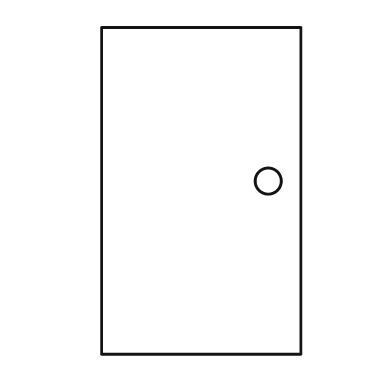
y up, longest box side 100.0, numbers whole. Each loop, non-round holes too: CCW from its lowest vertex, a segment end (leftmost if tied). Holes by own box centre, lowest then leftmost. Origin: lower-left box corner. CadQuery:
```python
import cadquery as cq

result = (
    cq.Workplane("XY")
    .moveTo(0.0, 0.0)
    .lineTo(61.0, 0.0)
    .lineTo(61.0, 100.0)
    .lineTo(0.0, 100.0)
    .close()
    .moveTo(51.0, 53.0)
    .circle(4.0)
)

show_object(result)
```